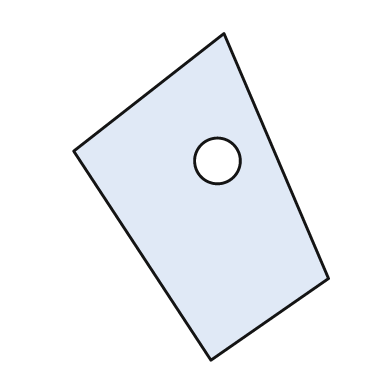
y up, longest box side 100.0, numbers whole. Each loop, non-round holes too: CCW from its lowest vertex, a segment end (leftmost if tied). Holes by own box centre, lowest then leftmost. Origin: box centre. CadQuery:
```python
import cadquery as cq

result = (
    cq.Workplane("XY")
    .moveTo(3.0, -50.0)
    .lineTo(39.0, -25.0)
    .lineTo(7.0, 50.0)
    .lineTo(-39.0, 14.0)
    .close()
    .moveTo(5.0, 11.0)
    .circle(7.0)
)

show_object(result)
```